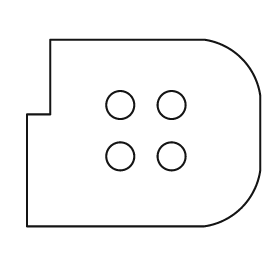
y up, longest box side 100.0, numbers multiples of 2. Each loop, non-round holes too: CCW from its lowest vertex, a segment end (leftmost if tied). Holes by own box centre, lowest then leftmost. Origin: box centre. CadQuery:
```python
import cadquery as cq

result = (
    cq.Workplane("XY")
    .moveTo(-50.0, -40.0)
    .lineTo(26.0, -40.0)
    .threePointArc((42.0, -32.0), (50.0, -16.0))
    .lineTo(50.0, 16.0)
    .threePointArc((42.0, 32.0), (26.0, 40.0))
    .lineTo(-40.0, 40.0)
    .lineTo(-40.0, 8.0)
    .lineTo(-50.0, 8.0)
    .close()
    .moveTo(-10.0, -10.0)
    .circle(6.0)
    .moveTo(12.0, -10.0)
    .circle(6.0)
    .moveTo(-10.0, 12.0)
    .circle(6.0)
    .moveTo(12.0, 12.0)
    .circle(6.0)
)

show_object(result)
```